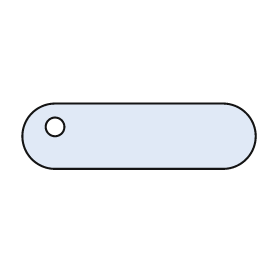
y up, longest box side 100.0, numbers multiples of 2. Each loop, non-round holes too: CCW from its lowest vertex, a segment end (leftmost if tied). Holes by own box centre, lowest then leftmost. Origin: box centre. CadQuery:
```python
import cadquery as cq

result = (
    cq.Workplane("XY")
    .moveTo(-36.0, -14.0)
    .lineTo(36.0, -14.0)
    .threePointArc((50.0, 0.0), (36.0, 14.0))
    .lineTo(-36.0, 14.0)
    .threePointArc((-50.0, 0.0), (-36.0, -14.0))
    .close()
    .moveTo(-36.0, 4.0)
    .circle(4.0)
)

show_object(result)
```